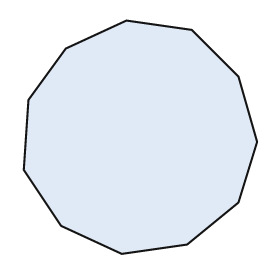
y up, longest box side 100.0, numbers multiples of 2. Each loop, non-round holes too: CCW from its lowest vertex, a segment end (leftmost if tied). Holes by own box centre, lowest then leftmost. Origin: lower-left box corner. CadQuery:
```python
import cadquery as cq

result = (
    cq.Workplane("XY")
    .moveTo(42.0, 0.0)
    .lineTo(70.0, 4.0)
    .lineTo(92.0, 22.0)
    .lineTo(100.0, 48.0)
    .lineTo(92.0, 76.0)
    .lineTo(72.0, 96.0)
    .lineTo(44.0, 100.0)
    .lineTo(18.0, 88.0)
    .lineTo(2.0, 66.0)
    .lineTo(0.0, 36.0)
    .lineTo(16.0, 12.0)
    .close()
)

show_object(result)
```